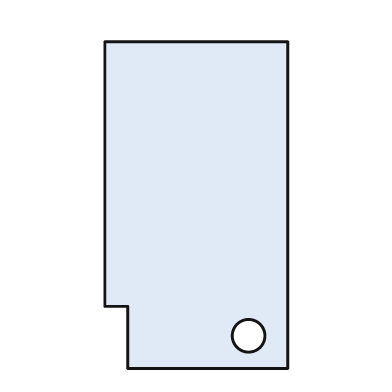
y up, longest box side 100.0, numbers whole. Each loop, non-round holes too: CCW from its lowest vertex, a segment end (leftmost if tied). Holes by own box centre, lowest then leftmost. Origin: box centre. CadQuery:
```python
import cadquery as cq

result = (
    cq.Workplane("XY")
    .moveTo(-21.0, -50.0)
    .lineTo(28.0, -50.0)
    .lineTo(28.0, 50.0)
    .lineTo(-28.0, 50.0)
    .lineTo(-28.0, -31.0)
    .lineTo(-21.0, -31.0)
    .close()
    .moveTo(16.0, -40.0)
    .circle(5.0)
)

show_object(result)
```